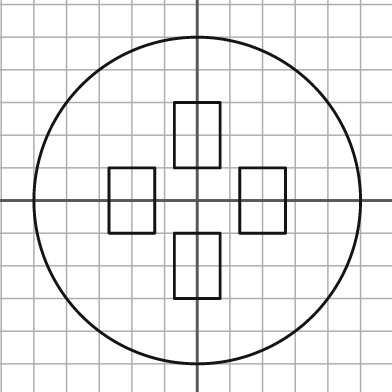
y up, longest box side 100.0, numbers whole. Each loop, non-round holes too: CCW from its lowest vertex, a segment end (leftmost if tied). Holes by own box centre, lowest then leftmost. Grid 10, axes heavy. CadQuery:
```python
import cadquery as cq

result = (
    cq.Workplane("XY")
    .moveTo(0.0, 0.0)
    .circle(50.0)
    .moveTo(-7.0, -30.0)
    .lineTo(7.0, -30.0)
    .lineTo(7.0, -10.0)
    .lineTo(-7.0, -10.0)
    .close()
    .moveTo(-27.0, -10.0)
    .lineTo(-13.0, -10.0)
    .lineTo(-13.0, 10.0)
    .lineTo(-27.0, 10.0)
    .close()
    .moveTo(13.0, -10.0)
    .lineTo(27.0, -10.0)
    .lineTo(27.0, 10.0)
    .lineTo(13.0, 10.0)
    .close()
    .moveTo(-7.0, 10.0)
    .lineTo(7.0, 10.0)
    .lineTo(7.0, 30.0)
    .lineTo(-7.0, 30.0)
    .close()
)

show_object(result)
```